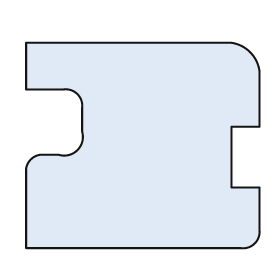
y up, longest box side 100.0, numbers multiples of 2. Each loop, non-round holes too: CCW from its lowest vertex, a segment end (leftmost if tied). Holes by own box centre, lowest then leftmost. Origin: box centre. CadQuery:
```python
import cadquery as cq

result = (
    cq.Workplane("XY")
    .moveTo(-50.0, -44.0)
    .lineTo(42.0, -44.0)
    .threePointArc((48.0, -42.0), (50.0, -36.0))
    .lineTo(50.0, -18.0)
    .lineTo(38.0, -18.0)
    .lineTo(38.0, 8.0)
    .lineTo(50.0, 8.0)
    .lineTo(50.0, 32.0)
    .threePointArc((46.0, 40.0), (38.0, 44.0))
    .lineTo(-50.0, 44.0)
    .lineTo(-50.0, 24.0)
    .lineTo(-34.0, 24.0)
    .threePointArc((-28.0, 22.0), (-26.0, 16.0))
    .lineTo(-26.0, 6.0)
    .threePointArc((-28.0, -2.0), (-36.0, -4.0))
    .lineTo(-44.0, -4.0)
    .threePointArc((-48.0, -6.0), (-50.0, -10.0))
    .close()
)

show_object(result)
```